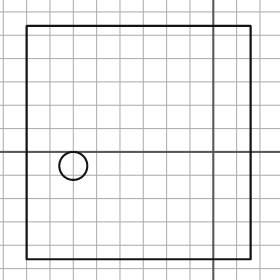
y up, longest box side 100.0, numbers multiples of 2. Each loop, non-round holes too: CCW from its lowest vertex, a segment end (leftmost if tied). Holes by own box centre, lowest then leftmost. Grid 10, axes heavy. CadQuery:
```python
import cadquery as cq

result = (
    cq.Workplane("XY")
    .moveTo(-80.0, -46.0)
    .lineTo(16.0, -46.0)
    .lineTo(16.0, 54.0)
    .lineTo(-80.0, 54.0)
    .close()
    .moveTo(-60.0, -6.0)
    .circle(6.0)
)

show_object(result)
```